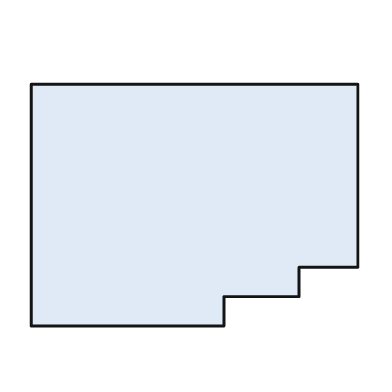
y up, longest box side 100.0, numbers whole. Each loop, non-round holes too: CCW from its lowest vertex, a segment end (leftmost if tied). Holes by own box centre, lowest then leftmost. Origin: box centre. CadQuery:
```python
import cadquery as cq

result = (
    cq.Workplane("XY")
    .moveTo(-50.0, -37.0)
    .lineTo(9.0, -37.0)
    .lineTo(9.0, -28.0)
    .lineTo(32.0, -28.0)
    .lineTo(32.0, -19.0)
    .lineTo(50.0, -19.0)
    .lineTo(50.0, 37.0)
    .lineTo(-50.0, 37.0)
    .close()
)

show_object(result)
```